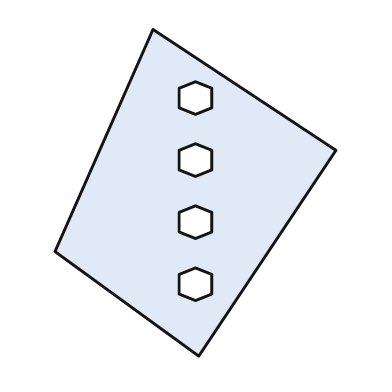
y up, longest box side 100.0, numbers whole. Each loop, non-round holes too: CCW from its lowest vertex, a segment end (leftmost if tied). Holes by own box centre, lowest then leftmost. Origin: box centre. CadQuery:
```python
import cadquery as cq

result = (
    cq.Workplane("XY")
    .moveTo(1.0, -50.0)
    .lineTo(43.0, 13.0)
    .lineTo(-13.0, 50.0)
    .lineTo(-43.0, -18.0)
    .close()
    .moveTo(0.0, -33.0)
    .lineTo(5.0, -31.0)
    .lineTo(5.0, -25.0)
    .lineTo(0.0, -23.0)
    .lineTo(-5.0, -25.0)
    .lineTo(-5.0, -31.0)
    .close()
    .moveTo(0.0, -14.0)
    .lineTo(5.0, -12.0)
    .lineTo(5.0, -6.0)
    .lineTo(0.0, -4.0)
    .lineTo(-5.0, -6.0)
    .lineTo(-5.0, -12.0)
    .close()
    .moveTo(0.0, 5.0)
    .lineTo(5.0, 7.0)
    .lineTo(5.0, 13.0)
    .lineTo(0.0, 15.0)
    .lineTo(-5.0, 13.0)
    .lineTo(-5.0, 7.0)
    .close()
    .moveTo(0.0, 24.0)
    .lineTo(5.0, 26.0)
    .lineTo(5.0, 32.0)
    .lineTo(0.0, 34.0)
    .lineTo(-5.0, 32.0)
    .lineTo(-5.0, 26.0)
    .close()
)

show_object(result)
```